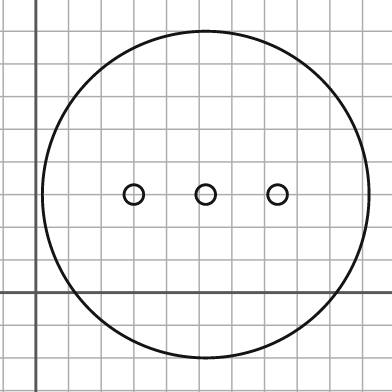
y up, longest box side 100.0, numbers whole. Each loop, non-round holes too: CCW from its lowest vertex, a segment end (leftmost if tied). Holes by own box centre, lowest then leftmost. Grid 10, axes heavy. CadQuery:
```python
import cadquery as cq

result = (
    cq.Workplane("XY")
    .moveTo(52.0, 30.0)
    .circle(50.0)
    .moveTo(30.0, 30.0)
    .circle(3.0)
    .moveTo(52.0, 30.0)
    .circle(3.0)
    .moveTo(74.0, 30.0)
    .circle(3.0)
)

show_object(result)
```